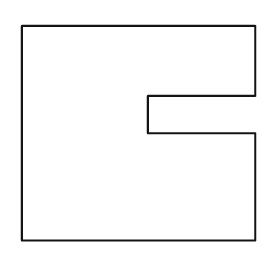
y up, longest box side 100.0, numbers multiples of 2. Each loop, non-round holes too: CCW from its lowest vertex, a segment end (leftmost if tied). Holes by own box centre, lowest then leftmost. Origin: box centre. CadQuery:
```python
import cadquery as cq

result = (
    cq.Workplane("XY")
    .moveTo(-50.0, -46.0)
    .lineTo(50.0, -46.0)
    .lineTo(50.0, 0.0)
    .lineTo(4.0, 0.0)
    .lineTo(4.0, 16.0)
    .lineTo(50.0, 16.0)
    .lineTo(50.0, 46.0)
    .lineTo(-50.0, 46.0)
    .close()
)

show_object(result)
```